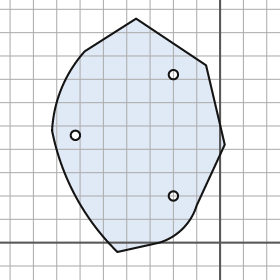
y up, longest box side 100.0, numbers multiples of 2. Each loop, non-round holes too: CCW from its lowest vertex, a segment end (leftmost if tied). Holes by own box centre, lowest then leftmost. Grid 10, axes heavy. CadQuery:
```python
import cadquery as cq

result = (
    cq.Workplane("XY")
    .moveTo(-44.0, -4.0)
    .lineTo(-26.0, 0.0)
    .threePointArc((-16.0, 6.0), (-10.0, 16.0))
    .lineTo(2.0, 42.0)
    .lineTo(-6.0, 76.0)
    .lineTo(-36.0, 96.0)
    .lineTo(-58.0, 82.0)
    .threePointArc((-68.0, 66.0), (-72.0, 48.0))
    .threePointArc((-62.0, 20.0), (-44.0, -4.0))
    .close()
    .moveTo(-20.0, 20.0)
    .circle(2.0)
    .moveTo(-62.0, 46.0)
    .circle(2.0)
    .moveTo(-20.0, 72.0)
    .circle(2.0)
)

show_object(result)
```